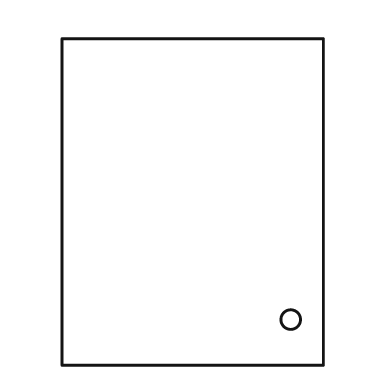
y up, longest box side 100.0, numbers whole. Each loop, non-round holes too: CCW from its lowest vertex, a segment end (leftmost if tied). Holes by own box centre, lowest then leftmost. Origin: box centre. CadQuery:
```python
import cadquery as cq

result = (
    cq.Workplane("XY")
    .moveTo(-40.0, -50.0)
    .lineTo(40.0, -50.0)
    .lineTo(40.0, 50.0)
    .lineTo(-40.0, 50.0)
    .close()
    .moveTo(30.0, -36.0)
    .circle(3.0)
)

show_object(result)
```